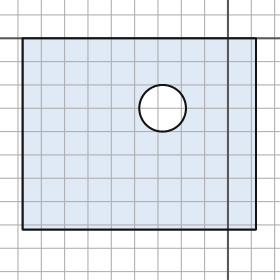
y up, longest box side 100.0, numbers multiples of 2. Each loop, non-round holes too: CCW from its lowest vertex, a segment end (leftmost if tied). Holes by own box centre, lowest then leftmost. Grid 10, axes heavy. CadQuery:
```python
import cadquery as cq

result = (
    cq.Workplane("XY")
    .moveTo(-88.0, -82.0)
    .lineTo(12.0, -82.0)
    .lineTo(12.0, 0.0)
    .lineTo(-88.0, 0.0)
    .close()
    .moveTo(-28.0, -30.0)
    .circle(10.0)
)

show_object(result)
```